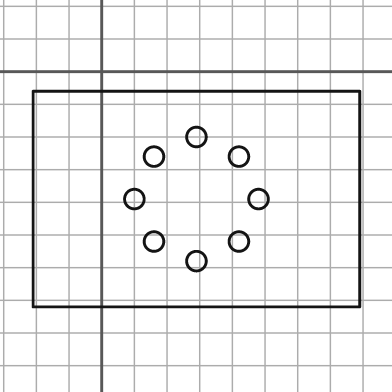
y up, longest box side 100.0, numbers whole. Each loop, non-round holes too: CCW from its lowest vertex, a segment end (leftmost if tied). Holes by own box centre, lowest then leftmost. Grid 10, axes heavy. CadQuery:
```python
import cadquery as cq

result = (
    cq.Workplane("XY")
    .moveTo(-21.0, -72.0)
    .lineTo(79.0, -72.0)
    .lineTo(79.0, -6.0)
    .lineTo(-21.0, -6.0)
    .close()
    .moveTo(29.0, -58.0)
    .circle(3.0)
    .moveTo(16.0, -52.0)
    .circle(3.0)
    .moveTo(42.0, -52.0)
    .circle(3.0)
    .moveTo(10.0, -39.0)
    .circle(3.0)
    .moveTo(48.0, -39.0)
    .circle(3.0)
    .moveTo(16.0, -26.0)
    .circle(3.0)
    .moveTo(42.0, -26.0)
    .circle(3.0)
    .moveTo(29.0, -20.0)
    .circle(3.0)
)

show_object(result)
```